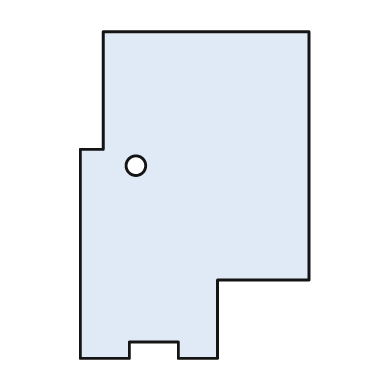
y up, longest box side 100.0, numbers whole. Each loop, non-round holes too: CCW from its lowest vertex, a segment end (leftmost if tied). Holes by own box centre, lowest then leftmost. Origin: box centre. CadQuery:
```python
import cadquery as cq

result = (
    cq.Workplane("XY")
    .moveTo(-35.0, -50.0)
    .lineTo(-20.0, -50.0)
    .lineTo(-20.0, -45.0)
    .lineTo(-5.0, -45.0)
    .lineTo(-5.0, -50.0)
    .lineTo(7.0, -50.0)
    .lineTo(7.0, -26.0)
    .lineTo(35.0, -26.0)
    .lineTo(35.0, 50.0)
    .lineTo(-28.0, 50.0)
    .lineTo(-28.0, 14.0)
    .lineTo(-35.0, 14.0)
    .close()
    .moveTo(-18.0, 9.0)
    .circle(3.0)
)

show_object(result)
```